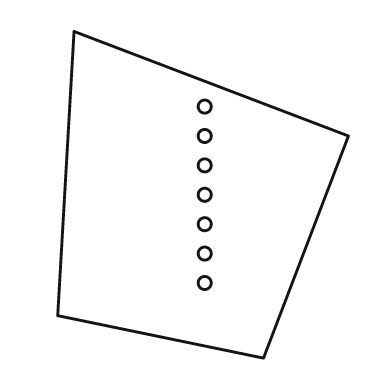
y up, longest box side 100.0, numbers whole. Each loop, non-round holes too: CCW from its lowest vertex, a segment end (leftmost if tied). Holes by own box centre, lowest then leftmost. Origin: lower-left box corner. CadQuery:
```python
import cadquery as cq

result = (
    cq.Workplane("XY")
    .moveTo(63.0, 0.0)
    .lineTo(89.0, 68.0)
    .lineTo(5.0, 100.0)
    .lineTo(0.0, 13.0)
    .close()
    .moveTo(45.0, 23.0)
    .circle(2.0)
    .moveTo(45.0, 32.0)
    .circle(2.0)
    .moveTo(45.0, 41.0)
    .circle(2.0)
    .moveTo(45.0, 50.0)
    .circle(2.0)
    .moveTo(45.0, 59.0)
    .circle(2.0)
    .moveTo(45.0, 68.0)
    .circle(2.0)
    .moveTo(45.0, 77.0)
    .circle(2.0)
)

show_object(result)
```